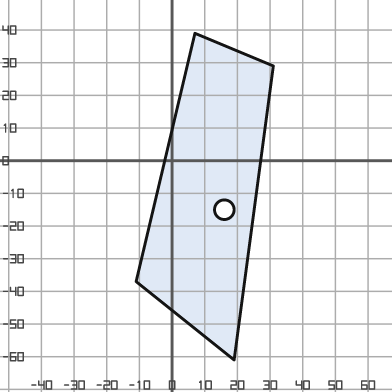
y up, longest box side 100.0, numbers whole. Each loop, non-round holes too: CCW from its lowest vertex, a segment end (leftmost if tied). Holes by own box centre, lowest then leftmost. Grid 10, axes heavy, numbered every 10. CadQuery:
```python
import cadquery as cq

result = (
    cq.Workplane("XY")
    .moveTo(19.0, -61.0)
    .lineTo(31.0, 29.0)
    .lineTo(7.0, 39.0)
    .lineTo(-11.0, -37.0)
    .close()
    .moveTo(16.0, -15.0)
    .circle(3.0)
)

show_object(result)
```